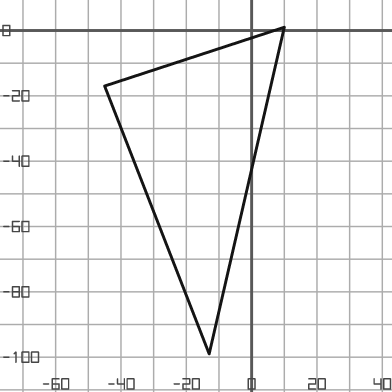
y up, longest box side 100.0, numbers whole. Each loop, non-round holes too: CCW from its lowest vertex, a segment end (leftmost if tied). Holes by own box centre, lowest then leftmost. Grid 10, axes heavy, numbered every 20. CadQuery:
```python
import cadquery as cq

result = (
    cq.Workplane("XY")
    .moveTo(-13.0, -99.0)
    .lineTo(10.0, 1.0)
    .lineTo(-45.0, -17.0)
    .close()
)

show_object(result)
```